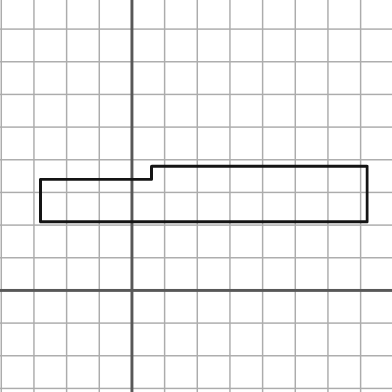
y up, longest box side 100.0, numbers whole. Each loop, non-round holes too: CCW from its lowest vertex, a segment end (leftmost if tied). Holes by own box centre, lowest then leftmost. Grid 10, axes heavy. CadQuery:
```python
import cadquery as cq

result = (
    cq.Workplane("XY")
    .moveTo(-28.0, 21.0)
    .lineTo(72.0, 21.0)
    .lineTo(72.0, 38.0)
    .lineTo(6.0, 38.0)
    .lineTo(6.0, 34.0)
    .lineTo(-28.0, 34.0)
    .close()
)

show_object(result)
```